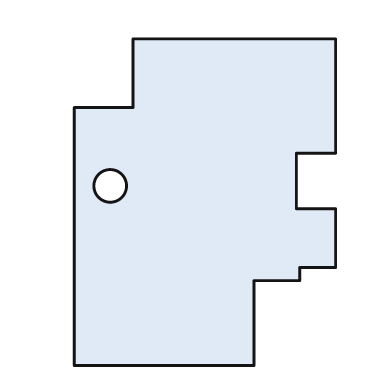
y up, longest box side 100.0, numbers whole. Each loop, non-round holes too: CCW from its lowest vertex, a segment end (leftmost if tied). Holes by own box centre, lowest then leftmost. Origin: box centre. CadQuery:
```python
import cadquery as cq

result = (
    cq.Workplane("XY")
    .moveTo(-40.0, -50.0)
    .lineTo(15.0, -50.0)
    .lineTo(15.0, -24.0)
    .lineTo(29.0, -24.0)
    .lineTo(29.0, -20.0)
    .lineTo(40.0, -20.0)
    .lineTo(40.0, -2.0)
    .lineTo(28.0, -2.0)
    .lineTo(28.0, 15.0)
    .lineTo(40.0, 15.0)
    .lineTo(40.0, 50.0)
    .lineTo(-22.0, 50.0)
    .lineTo(-22.0, 29.0)
    .lineTo(-40.0, 29.0)
    .close()
    .moveTo(-29.0, 5.0)
    .circle(5.0)
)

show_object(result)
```